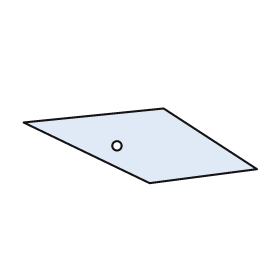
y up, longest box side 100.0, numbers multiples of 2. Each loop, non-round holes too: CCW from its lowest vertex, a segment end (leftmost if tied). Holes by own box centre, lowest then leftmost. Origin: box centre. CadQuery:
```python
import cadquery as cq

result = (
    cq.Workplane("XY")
    .moveTo(4.0, -16.0)
    .lineTo(50.0, -10.0)
    .lineTo(10.0, 16.0)
    .lineTo(-50.0, 10.0)
    .close()
    .moveTo(-10.0, 0.0)
    .circle(2.0)
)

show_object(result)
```